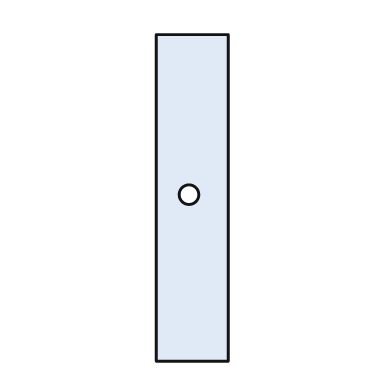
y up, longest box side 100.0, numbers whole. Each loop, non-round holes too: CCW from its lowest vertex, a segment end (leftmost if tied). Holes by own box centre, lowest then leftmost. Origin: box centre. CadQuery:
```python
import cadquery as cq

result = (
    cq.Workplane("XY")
    .moveTo(-11.0, -50.0)
    .lineTo(11.0, -50.0)
    .lineTo(11.0, 50.0)
    .lineTo(-11.0, 50.0)
    .close()
    .moveTo(-1.0, 1.0)
    .circle(3.0)
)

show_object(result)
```